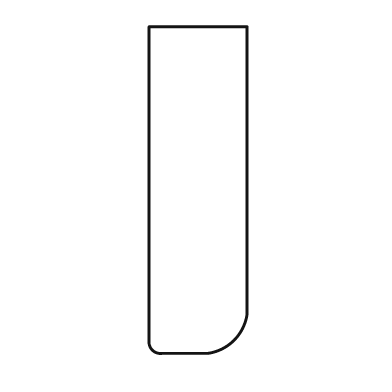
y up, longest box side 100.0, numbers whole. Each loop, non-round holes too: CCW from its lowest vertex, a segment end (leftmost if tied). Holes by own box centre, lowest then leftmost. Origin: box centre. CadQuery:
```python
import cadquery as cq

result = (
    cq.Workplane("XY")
    .moveTo(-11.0, -50.0)
    .lineTo(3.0, -50.0)
    .threePointArc((11.0, -46.0), (15.0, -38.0))
    .lineTo(15.0, 50.0)
    .lineTo(-15.0, 50.0)
    .lineTo(-15.0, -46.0)
    .threePointArc((-14.0, -49.0), (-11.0, -50.0))
    .close()
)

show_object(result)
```